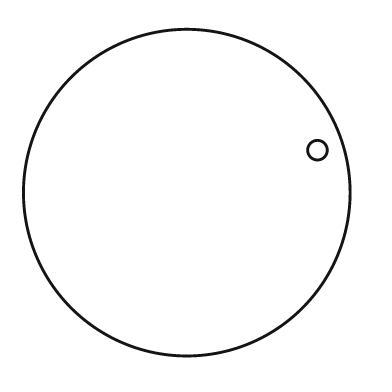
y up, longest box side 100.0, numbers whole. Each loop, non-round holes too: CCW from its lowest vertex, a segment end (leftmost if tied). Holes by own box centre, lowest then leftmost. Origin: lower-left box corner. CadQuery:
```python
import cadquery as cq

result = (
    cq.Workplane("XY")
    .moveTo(50.0, 50.0)
    .circle(50.0)
    .moveTo(90.0, 63.0)
    .circle(3.0)
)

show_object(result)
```